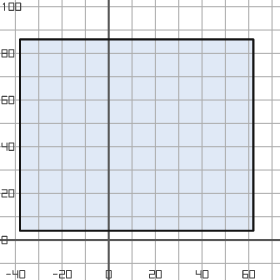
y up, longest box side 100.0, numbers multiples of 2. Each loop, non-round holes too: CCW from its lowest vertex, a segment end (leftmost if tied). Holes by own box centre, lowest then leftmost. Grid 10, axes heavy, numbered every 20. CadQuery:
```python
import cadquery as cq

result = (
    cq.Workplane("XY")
    .moveTo(-38.0, 4.0)
    .lineTo(62.0, 4.0)
    .lineTo(62.0, 86.0)
    .lineTo(-38.0, 86.0)
    .close()
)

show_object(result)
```